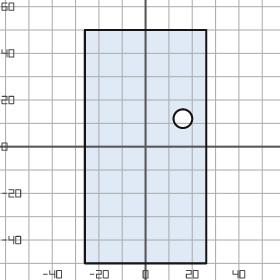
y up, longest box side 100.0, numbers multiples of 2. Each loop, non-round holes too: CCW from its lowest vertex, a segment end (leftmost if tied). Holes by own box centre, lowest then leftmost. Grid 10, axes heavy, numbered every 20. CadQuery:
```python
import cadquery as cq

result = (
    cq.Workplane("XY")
    .moveTo(-26.0, -50.0)
    .lineTo(26.0, -50.0)
    .lineTo(26.0, 50.0)
    .lineTo(-26.0, 50.0)
    .close()
    .moveTo(16.0, 12.0)
    .circle(4.0)
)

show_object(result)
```